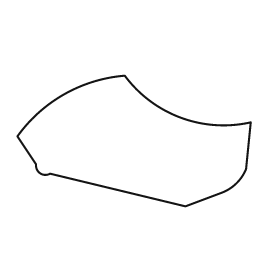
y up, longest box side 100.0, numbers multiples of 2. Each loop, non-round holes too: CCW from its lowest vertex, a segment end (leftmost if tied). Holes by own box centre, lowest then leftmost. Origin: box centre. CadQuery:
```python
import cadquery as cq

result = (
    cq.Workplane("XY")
    .moveTo(22.0, -28.0)
    .lineTo(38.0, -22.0)
    .threePointArc((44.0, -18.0), (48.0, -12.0))
    .lineTo(50.0, 8.0)
    .threePointArc((20.0, 10.0), (-4.0, 28.0))
    .threePointArc((-30.0, 20.0), (-50.0, 2.0))
    .lineTo(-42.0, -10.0)
    .threePointArc((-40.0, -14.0), (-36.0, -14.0))
    .close()
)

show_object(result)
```